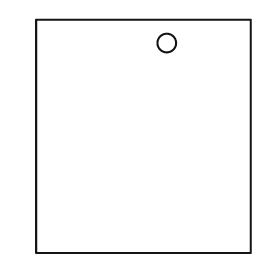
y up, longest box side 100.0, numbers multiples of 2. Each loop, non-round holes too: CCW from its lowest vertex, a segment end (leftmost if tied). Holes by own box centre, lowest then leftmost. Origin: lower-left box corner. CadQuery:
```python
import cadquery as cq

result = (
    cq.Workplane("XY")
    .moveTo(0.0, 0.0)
    .lineTo(92.0, 0.0)
    .lineTo(92.0, 100.0)
    .lineTo(0.0, 100.0)
    .close()
    .moveTo(56.0, 90.0)
    .circle(4.0)
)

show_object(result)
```